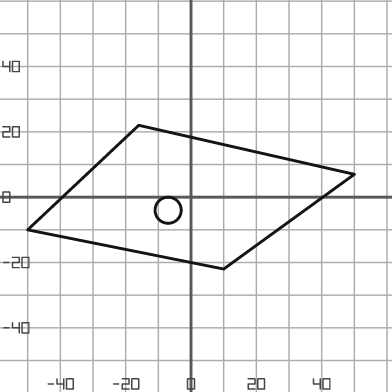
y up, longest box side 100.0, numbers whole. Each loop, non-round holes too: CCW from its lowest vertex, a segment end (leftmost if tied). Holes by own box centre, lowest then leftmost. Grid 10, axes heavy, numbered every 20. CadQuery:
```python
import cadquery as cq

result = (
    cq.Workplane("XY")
    .moveTo(10.0, -22.0)
    .lineTo(50.0, 7.0)
    .lineTo(-16.0, 22.0)
    .lineTo(-50.0, -10.0)
    .close()
    .moveTo(-7.0, -4.0)
    .circle(4.0)
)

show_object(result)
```